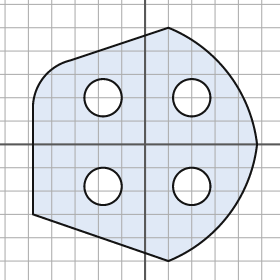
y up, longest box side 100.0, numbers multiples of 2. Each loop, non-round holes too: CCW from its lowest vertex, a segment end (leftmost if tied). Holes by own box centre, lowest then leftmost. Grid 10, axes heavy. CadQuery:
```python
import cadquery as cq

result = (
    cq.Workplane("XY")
    .moveTo(10.0, -50.0)
    .threePointArc((36.0, -30.0), (48.0, 0.0))
    .threePointArc((36.0, 30.0), (10.0, 50.0))
    .lineTo(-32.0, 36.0)
    .threePointArc((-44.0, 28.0), (-48.0, 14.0))
    .lineTo(-48.0, -30.0)
    .close()
    .moveTo(-18.0, -18.0)
    .circle(8.0)
    .moveTo(20.0, -18.0)
    .circle(8.0)
    .moveTo(-18.0, 20.0)
    .circle(8.0)
    .moveTo(20.0, 20.0)
    .circle(8.0)
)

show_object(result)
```